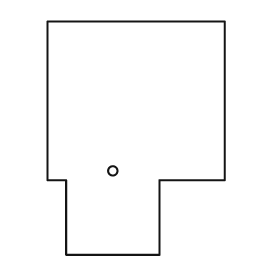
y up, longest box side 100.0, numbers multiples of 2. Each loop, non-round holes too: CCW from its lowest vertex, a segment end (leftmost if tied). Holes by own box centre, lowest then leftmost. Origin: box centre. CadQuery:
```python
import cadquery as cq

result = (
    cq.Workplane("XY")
    .moveTo(-30.0, -50.0)
    .lineTo(10.0, -50.0)
    .lineTo(10.0, -18.0)
    .lineTo(38.0, -18.0)
    .lineTo(38.0, 50.0)
    .lineTo(-38.0, 50.0)
    .lineTo(-38.0, -18.0)
    .lineTo(-30.0, -18.0)
    .close()
    .moveTo(-10.0, -14.0)
    .circle(2.0)
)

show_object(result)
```